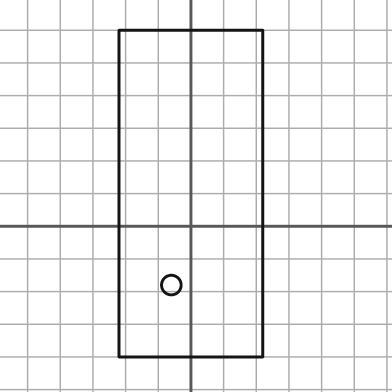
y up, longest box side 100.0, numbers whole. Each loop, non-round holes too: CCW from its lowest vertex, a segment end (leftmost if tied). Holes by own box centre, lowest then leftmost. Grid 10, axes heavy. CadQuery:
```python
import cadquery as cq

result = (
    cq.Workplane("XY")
    .moveTo(-22.0, -40.0)
    .lineTo(22.0, -40.0)
    .lineTo(22.0, 60.0)
    .lineTo(-22.0, 60.0)
    .close()
    .moveTo(-6.0, -18.0)
    .circle(3.0)
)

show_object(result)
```